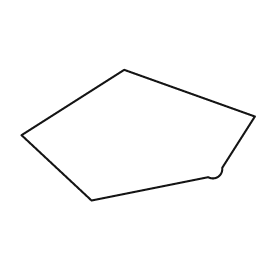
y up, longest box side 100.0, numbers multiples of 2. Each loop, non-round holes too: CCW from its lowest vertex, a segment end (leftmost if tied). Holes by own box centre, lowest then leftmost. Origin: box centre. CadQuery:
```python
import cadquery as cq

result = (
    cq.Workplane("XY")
    .moveTo(-20.0, -28.0)
    .lineTo(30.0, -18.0)
    .threePointArc((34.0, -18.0), (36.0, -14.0))
    .lineTo(50.0, 8.0)
    .lineTo(-6.0, 28.0)
    .lineTo(-50.0, 0.0)
    .close()
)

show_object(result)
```